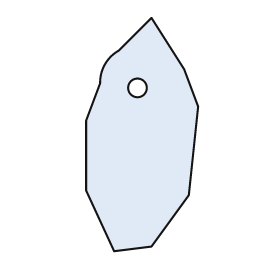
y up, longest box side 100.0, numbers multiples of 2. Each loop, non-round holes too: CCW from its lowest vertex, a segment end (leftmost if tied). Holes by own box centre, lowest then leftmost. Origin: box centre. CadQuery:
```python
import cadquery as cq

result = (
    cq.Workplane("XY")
    .moveTo(-12.0, -50.0)
    .lineTo(4.0, -48.0)
    .lineTo(20.0, -26.0)
    .lineTo(24.0, 12.0)
    .lineTo(18.0, 28.0)
    .lineTo(4.0, 50.0)
    .lineTo(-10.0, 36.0)
    .threePointArc((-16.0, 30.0), (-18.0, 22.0))
    .lineTo(-24.0, 6.0)
    .lineTo(-24.0, -24.0)
    .close()
    .moveTo(-2.0, 20.0)
    .circle(4.0)
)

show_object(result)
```